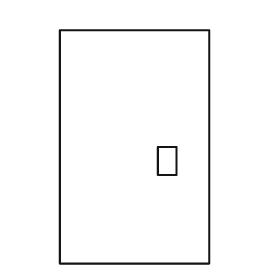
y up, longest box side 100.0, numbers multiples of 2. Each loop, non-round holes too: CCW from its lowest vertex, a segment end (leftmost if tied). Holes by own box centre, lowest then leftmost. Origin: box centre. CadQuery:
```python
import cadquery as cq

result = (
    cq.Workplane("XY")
    .moveTo(-32.0, -50.0)
    .lineTo(32.0, -50.0)
    .lineTo(32.0, 50.0)
    .lineTo(-32.0, 50.0)
    .close()
    .moveTo(10.0, -12.0)
    .lineTo(18.0, -12.0)
    .lineTo(18.0, 0.0)
    .lineTo(10.0, 0.0)
    .close()
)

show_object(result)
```